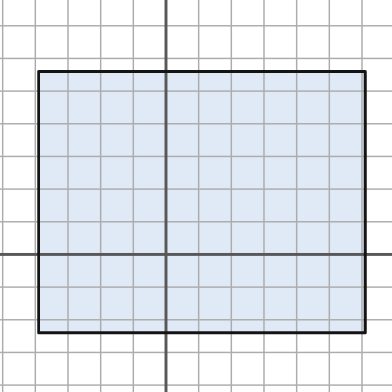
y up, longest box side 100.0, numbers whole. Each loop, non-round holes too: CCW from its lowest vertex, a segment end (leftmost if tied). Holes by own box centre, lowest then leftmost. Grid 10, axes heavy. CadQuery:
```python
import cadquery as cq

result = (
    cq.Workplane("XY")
    .moveTo(-39.0, -24.0)
    .lineTo(61.0, -24.0)
    .lineTo(61.0, 56.0)
    .lineTo(-39.0, 56.0)
    .close()
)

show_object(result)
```